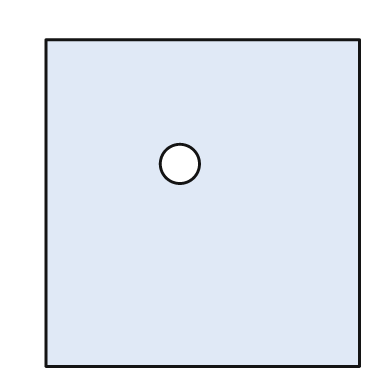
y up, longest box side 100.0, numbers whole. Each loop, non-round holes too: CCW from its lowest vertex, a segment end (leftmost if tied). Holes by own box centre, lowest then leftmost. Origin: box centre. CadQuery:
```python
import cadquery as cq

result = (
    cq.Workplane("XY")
    .moveTo(-48.0, -50.0)
    .lineTo(48.0, -50.0)
    .lineTo(48.0, 50.0)
    .lineTo(-48.0, 50.0)
    .close()
    .moveTo(-7.0, 12.0)
    .circle(6.0)
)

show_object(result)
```